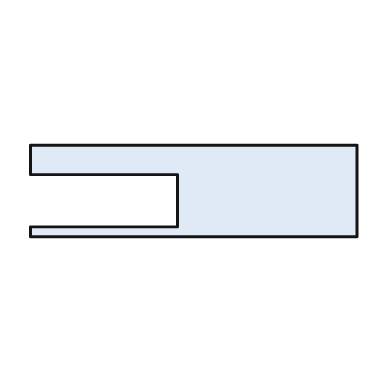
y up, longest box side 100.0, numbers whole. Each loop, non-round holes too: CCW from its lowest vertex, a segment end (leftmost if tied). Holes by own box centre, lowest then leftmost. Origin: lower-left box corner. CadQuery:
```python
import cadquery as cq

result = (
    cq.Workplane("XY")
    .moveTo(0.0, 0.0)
    .lineTo(100.0, 0.0)
    .lineTo(100.0, 28.0)
    .lineTo(0.0, 28.0)
    .lineTo(0.0, 19.0)
    .lineTo(45.0, 19.0)
    .lineTo(45.0, 3.0)
    .lineTo(0.0, 3.0)
    .close()
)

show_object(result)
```